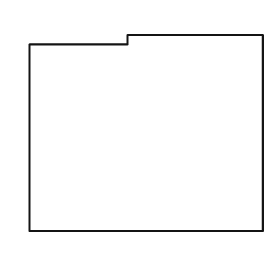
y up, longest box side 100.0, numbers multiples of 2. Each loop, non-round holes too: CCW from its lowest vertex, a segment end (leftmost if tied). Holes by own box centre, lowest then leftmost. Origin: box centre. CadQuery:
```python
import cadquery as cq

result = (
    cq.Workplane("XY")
    .moveTo(-50.0, -42.0)
    .lineTo(50.0, -42.0)
    .lineTo(50.0, 42.0)
    .lineTo(-8.0, 42.0)
    .lineTo(-8.0, 38.0)
    .lineTo(-50.0, 38.0)
    .close()
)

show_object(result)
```